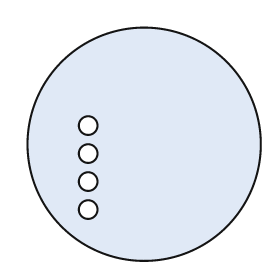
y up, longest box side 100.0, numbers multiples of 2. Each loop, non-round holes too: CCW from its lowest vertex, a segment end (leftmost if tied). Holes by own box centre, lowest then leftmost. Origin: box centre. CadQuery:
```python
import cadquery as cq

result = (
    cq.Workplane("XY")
    .moveTo(0.0, 0.0)
    .circle(50.0)
    .moveTo(-24.0, -28.0)
    .circle(4.0)
    .moveTo(-24.0, -16.0)
    .circle(4.0)
    .moveTo(-24.0, -4.0)
    .circle(4.0)
    .moveTo(-24.0, 8.0)
    .circle(4.0)
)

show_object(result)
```